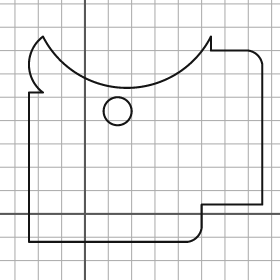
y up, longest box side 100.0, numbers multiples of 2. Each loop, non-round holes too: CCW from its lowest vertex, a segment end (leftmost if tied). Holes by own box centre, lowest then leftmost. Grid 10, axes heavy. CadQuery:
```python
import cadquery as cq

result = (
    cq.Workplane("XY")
    .moveTo(-24.0, -12.0)
    .lineTo(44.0, -12.0)
    .threePointArc((48.0, -10.0), (50.0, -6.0))
    .lineTo(50.0, 4.0)
    .lineTo(76.0, 4.0)
    .lineTo(76.0, 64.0)
    .threePointArc((74.0, 68.0), (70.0, 70.0))
    .lineTo(54.0, 70.0)
    .lineTo(54.0, 76.0)
    .threePointArc((18.0, 54.0), (-18.0, 76.0))
    .threePointArc((-24.0, 64.0), (-18.0, 52.0))
    .lineTo(-24.0, 52.0)
    .close()
    .moveTo(14.0, 44.0)
    .circle(6.0)
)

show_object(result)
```